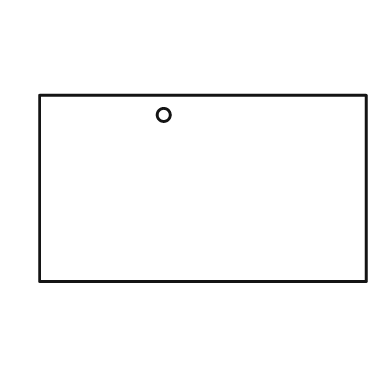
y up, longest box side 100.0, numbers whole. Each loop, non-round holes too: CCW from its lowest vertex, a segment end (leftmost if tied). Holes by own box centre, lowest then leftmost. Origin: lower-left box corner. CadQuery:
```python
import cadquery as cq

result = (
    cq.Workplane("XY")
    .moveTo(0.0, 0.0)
    .lineTo(100.0, 0.0)
    .lineTo(100.0, 57.0)
    .lineTo(0.0, 57.0)
    .close()
    .moveTo(38.0, 51.0)
    .circle(2.0)
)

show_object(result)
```